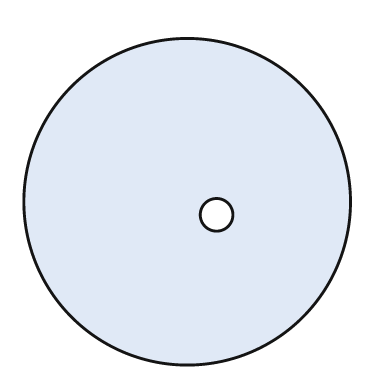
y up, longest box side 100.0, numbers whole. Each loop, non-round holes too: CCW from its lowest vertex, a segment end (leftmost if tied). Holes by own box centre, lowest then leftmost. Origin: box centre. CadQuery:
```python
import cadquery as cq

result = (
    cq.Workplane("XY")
    .moveTo(0.0, 0.0)
    .circle(50.0)
    .moveTo(9.0, -4.0)
    .circle(5.0)
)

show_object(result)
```